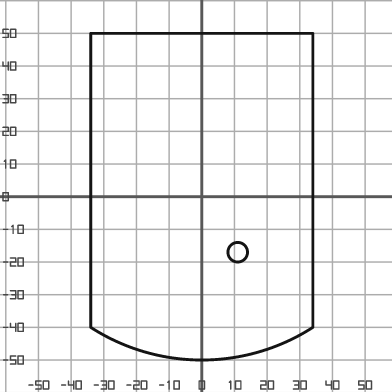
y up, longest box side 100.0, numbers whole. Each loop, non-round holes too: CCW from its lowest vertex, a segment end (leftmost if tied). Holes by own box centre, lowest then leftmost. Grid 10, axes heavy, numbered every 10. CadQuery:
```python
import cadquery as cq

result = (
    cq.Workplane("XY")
    .moveTo(-34.0, -40.0)
    .threePointArc((0.0, -50.0), (34.0, -40.0))
    .lineTo(34.0, 50.0)
    .lineTo(-34.0, 50.0)
    .close()
    .moveTo(11.0, -17.0)
    .circle(3.0)
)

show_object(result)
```